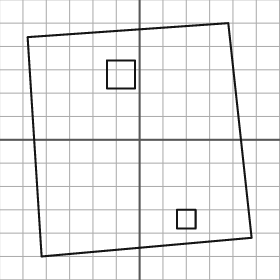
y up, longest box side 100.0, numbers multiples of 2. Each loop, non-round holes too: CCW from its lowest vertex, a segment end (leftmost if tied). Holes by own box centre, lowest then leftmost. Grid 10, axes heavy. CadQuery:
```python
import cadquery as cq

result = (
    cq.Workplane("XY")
    .moveTo(-42.0, -50.0)
    .lineTo(48.0, -42.0)
    .lineTo(38.0, 50.0)
    .lineTo(-48.0, 44.0)
    .close()
    .moveTo(16.0, -38.0)
    .lineTo(24.0, -38.0)
    .lineTo(24.0, -30.0)
    .lineTo(16.0, -30.0)
    .close()
    .moveTo(-14.0, 22.0)
    .lineTo(-2.0, 22.0)
    .lineTo(-2.0, 34.0)
    .lineTo(-14.0, 34.0)
    .close()
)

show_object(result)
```